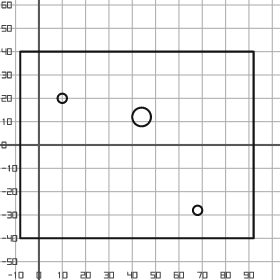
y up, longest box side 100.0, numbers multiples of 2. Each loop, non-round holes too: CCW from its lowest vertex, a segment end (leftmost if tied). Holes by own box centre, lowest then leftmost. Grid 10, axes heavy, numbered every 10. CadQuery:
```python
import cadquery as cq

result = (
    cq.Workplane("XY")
    .moveTo(-8.0, -40.0)
    .lineTo(92.0, -40.0)
    .lineTo(92.0, 40.0)
    .lineTo(-8.0, 40.0)
    .close()
    .moveTo(68.0, -28.0)
    .circle(2.0)
    .moveTo(44.0, 12.0)
    .circle(4.0)
    .moveTo(10.0, 20.0)
    .circle(2.0)
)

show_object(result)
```